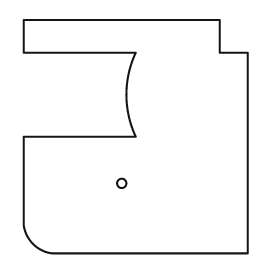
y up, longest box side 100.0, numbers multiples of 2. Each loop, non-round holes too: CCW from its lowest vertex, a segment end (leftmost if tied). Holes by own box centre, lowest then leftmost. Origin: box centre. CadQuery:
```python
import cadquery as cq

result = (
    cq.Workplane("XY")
    .moveTo(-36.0, -50.0)
    .lineTo(48.0, -50.0)
    .lineTo(48.0, 36.0)
    .lineTo(36.0, 36.0)
    .lineTo(36.0, 50.0)
    .lineTo(-48.0, 50.0)
    .lineTo(-48.0, 36.0)
    .lineTo(0.0, 36.0)
    .threePointArc((-4.0, 18.0), (0.0, 0.0))
    .lineTo(-48.0, 0.0)
    .lineTo(-48.0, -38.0)
    .threePointArc((-44.0, -46.0), (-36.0, -50.0))
    .close()
    .moveTo(-6.0, -20.0)
    .circle(2.0)
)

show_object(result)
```